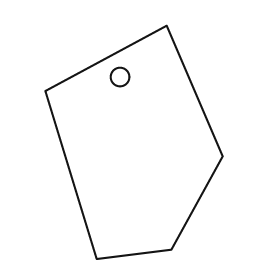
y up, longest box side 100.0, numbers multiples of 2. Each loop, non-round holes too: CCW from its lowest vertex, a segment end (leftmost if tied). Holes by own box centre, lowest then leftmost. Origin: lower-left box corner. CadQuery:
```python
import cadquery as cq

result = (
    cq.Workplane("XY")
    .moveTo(22.0, 0.0)
    .lineTo(54.0, 4.0)
    .lineTo(76.0, 44.0)
    .lineTo(52.0, 100.0)
    .lineTo(0.0, 72.0)
    .close()
    .moveTo(32.0, 78.0)
    .circle(4.0)
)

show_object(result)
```